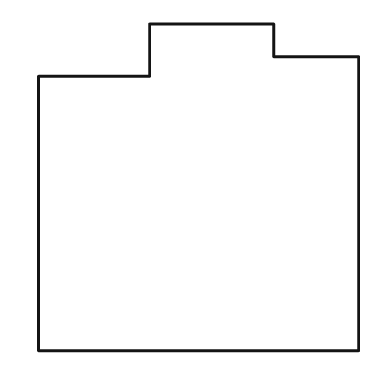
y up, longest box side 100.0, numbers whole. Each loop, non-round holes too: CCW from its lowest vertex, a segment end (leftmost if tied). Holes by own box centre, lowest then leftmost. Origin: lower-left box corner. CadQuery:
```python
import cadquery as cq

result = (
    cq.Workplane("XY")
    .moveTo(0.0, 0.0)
    .lineTo(98.0, 0.0)
    .lineTo(98.0, 90.0)
    .lineTo(72.0, 90.0)
    .lineTo(72.0, 100.0)
    .lineTo(34.0, 100.0)
    .lineTo(34.0, 84.0)
    .lineTo(0.0, 84.0)
    .close()
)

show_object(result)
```